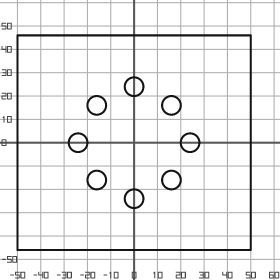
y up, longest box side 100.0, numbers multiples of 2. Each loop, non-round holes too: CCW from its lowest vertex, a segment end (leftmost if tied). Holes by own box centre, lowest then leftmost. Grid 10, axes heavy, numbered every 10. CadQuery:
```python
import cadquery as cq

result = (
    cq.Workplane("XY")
    .moveTo(-50.0, -46.0)
    .lineTo(50.0, -46.0)
    .lineTo(50.0, 46.0)
    .lineTo(-50.0, 46.0)
    .close()
    .moveTo(0.0, -24.0)
    .circle(4.0)
    .moveTo(-16.0, -16.0)
    .circle(4.0)
    .moveTo(16.0, -16.0)
    .circle(4.0)
    .moveTo(-24.0, 0.0)
    .circle(4.0)
    .moveTo(24.0, 0.0)
    .circle(4.0)
    .moveTo(-16.0, 16.0)
    .circle(4.0)
    .moveTo(16.0, 16.0)
    .circle(4.0)
    .moveTo(0.0, 24.0)
    .circle(4.0)
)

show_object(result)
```